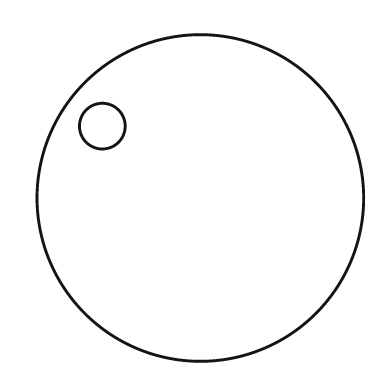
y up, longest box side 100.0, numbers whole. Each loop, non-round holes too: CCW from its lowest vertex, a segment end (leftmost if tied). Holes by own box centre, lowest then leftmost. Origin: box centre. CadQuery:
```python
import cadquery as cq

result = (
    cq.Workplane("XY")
    .moveTo(0.0, 0.0)
    .circle(50.0)
    .moveTo(-30.0, 22.0)
    .circle(7.0)
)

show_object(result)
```